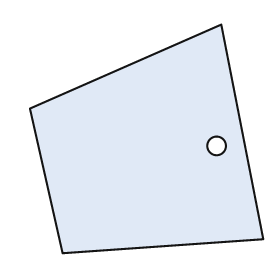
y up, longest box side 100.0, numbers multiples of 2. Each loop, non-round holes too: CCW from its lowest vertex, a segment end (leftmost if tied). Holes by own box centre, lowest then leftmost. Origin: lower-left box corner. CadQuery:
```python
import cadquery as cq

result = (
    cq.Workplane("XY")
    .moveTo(14.0, 0.0)
    .lineTo(100.0, 6.0)
    .lineTo(82.0, 98.0)
    .lineTo(0.0, 62.0)
    .close()
    .moveTo(80.0, 46.0)
    .circle(4.0)
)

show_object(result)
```